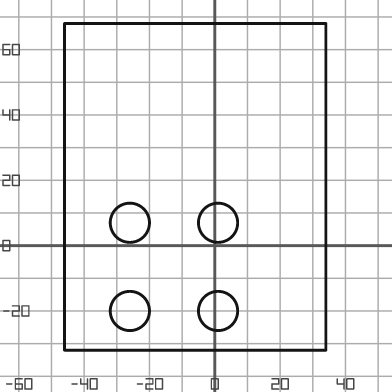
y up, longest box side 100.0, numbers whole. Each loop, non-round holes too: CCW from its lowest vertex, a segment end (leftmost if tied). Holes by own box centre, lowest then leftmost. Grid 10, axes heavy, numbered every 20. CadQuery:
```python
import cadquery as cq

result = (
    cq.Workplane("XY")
    .moveTo(-46.0, -32.0)
    .lineTo(34.0, -32.0)
    .lineTo(34.0, 68.0)
    .lineTo(-46.0, 68.0)
    .close()
    .moveTo(-26.0, -20.0)
    .circle(6.0)
    .moveTo(1.0, -20.0)
    .circle(6.0)
    .moveTo(-26.0, 7.0)
    .circle(6.0)
    .moveTo(1.0, 7.0)
    .circle(6.0)
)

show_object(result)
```